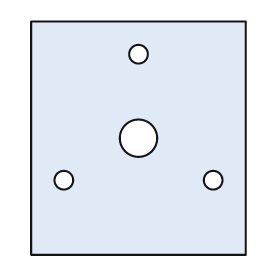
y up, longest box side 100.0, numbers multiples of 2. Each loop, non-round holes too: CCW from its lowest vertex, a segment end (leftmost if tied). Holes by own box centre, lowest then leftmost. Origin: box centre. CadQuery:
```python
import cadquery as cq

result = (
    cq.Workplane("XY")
    .moveTo(-46.0, -50.0)
    .lineTo(46.0, -50.0)
    .lineTo(46.0, 50.0)
    .lineTo(-46.0, 50.0)
    .close()
    .moveTo(-32.0, -18.0)
    .circle(4.0)
    .moveTo(32.0, -18.0)
    .circle(4.0)
    .moveTo(0.0, 0.0)
    .circle(8.0)
    .moveTo(0.0, 36.0)
    .circle(4.0)
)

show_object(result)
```